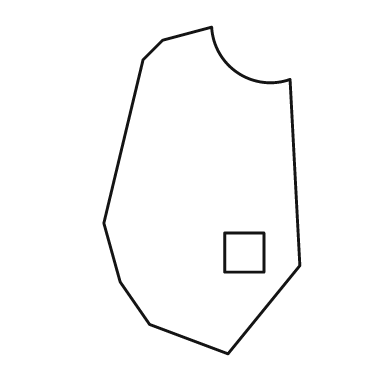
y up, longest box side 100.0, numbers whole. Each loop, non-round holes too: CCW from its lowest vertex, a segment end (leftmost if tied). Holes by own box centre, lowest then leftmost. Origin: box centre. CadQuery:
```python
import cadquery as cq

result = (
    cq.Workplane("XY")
    .moveTo(8.0, -50.0)
    .lineTo(30.0, -23.0)
    .lineTo(27.0, 34.0)
    .threePointArc((11.0, 36.0), (3.0, 50.0))
    .lineTo(-12.0, 46.0)
    .lineTo(-18.0, 40.0)
    .lineTo(-30.0, -10.0)
    .lineTo(-25.0, -28.0)
    .lineTo(-16.0, -41.0)
    .close()
    .moveTo(7.0, -25.0)
    .lineTo(19.0, -25.0)
    .lineTo(19.0, -13.0)
    .lineTo(7.0, -13.0)
    .close()
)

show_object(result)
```